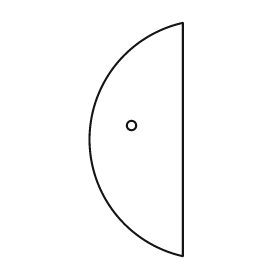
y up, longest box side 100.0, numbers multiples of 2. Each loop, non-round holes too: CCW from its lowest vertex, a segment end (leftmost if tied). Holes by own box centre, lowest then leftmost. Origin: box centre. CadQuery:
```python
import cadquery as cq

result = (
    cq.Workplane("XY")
    .moveTo(20.0, -50.0)
    .lineTo(20.0, 50.0)
    .threePointArc((-20.0, 0.0), (20.0, -50.0))
    .close()
    .moveTo(-2.0, 6.0)
    .circle(2.0)
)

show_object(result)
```